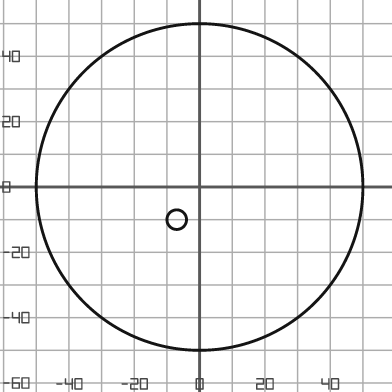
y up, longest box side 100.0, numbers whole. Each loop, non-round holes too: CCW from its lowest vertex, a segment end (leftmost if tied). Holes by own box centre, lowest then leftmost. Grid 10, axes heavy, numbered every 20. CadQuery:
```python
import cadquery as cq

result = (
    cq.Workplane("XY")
    .moveTo(0.0, 0.0)
    .circle(50.0)
    .moveTo(-7.0, -10.0)
    .circle(3.0)
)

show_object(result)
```